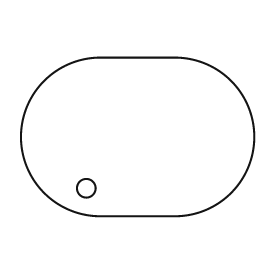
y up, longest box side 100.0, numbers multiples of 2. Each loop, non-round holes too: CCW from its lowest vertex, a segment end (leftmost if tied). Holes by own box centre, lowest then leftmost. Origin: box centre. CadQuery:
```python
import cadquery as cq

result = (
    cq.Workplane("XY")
    .moveTo(-16.0, -34.0)
    .lineTo(16.0, -34.0)
    .threePointArc((50.0, 0.0), (16.0, 34.0))
    .lineTo(-16.0, 34.0)
    .threePointArc((-50.0, 0.0), (-16.0, -34.0))
    .close()
    .moveTo(-22.0, -22.0)
    .circle(4.0)
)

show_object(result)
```